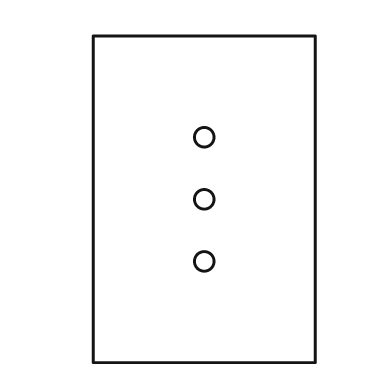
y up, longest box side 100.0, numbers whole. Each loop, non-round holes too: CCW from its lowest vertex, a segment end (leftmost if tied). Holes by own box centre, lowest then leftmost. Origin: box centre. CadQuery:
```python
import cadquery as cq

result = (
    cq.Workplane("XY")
    .moveTo(-34.0, -50.0)
    .lineTo(34.0, -50.0)
    .lineTo(34.0, 50.0)
    .lineTo(-34.0, 50.0)
    .close()
    .moveTo(0.0, -19.0)
    .circle(3.0)
    .moveTo(0.0, 0.0)
    .circle(3.0)
    .moveTo(0.0, 19.0)
    .circle(3.0)
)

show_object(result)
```